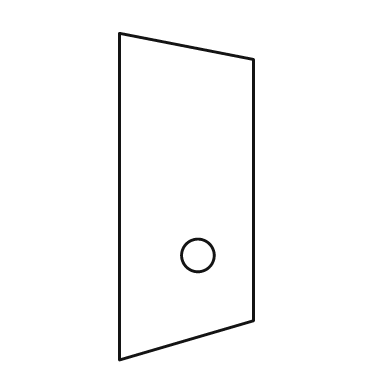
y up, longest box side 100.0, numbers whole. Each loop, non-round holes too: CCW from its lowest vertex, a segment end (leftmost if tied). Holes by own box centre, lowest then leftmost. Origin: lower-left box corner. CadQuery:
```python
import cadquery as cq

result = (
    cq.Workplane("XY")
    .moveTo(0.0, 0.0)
    .lineTo(41.0, 12.0)
    .lineTo(41.0, 92.0)
    .lineTo(0.0, 100.0)
    .close()
    .moveTo(24.0, 32.0)
    .circle(5.0)
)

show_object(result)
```